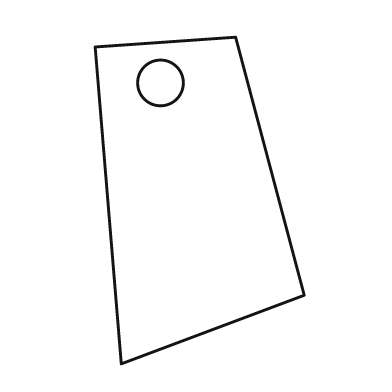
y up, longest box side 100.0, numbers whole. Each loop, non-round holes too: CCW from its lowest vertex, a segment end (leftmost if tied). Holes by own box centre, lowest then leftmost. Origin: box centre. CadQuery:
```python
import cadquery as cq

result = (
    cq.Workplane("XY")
    .moveTo(-24.0, -50.0)
    .lineTo(32.0, -29.0)
    .lineTo(11.0, 50.0)
    .lineTo(-32.0, 47.0)
    .close()
    .moveTo(-12.0, 36.0)
    .circle(7.0)
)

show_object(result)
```